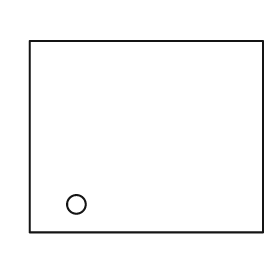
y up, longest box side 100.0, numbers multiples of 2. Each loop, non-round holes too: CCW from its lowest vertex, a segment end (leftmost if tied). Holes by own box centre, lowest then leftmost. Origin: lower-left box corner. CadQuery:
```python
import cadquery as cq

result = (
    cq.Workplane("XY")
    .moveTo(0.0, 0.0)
    .lineTo(100.0, 0.0)
    .lineTo(100.0, 82.0)
    .lineTo(0.0, 82.0)
    .close()
    .moveTo(20.0, 12.0)
    .circle(4.0)
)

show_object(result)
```